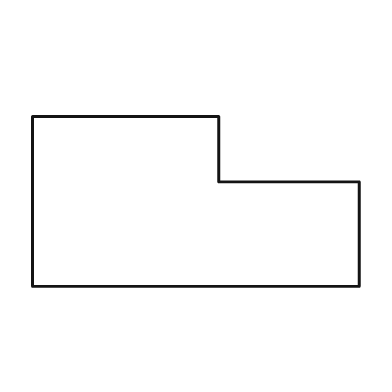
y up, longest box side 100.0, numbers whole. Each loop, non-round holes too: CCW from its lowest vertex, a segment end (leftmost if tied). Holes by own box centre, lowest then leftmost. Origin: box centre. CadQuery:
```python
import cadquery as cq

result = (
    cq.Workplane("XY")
    .moveTo(-50.0, -26.0)
    .lineTo(50.0, -26.0)
    .lineTo(50.0, 6.0)
    .lineTo(7.0, 6.0)
    .lineTo(7.0, 26.0)
    .lineTo(-50.0, 26.0)
    .close()
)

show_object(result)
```